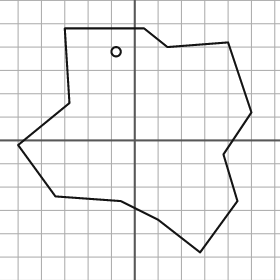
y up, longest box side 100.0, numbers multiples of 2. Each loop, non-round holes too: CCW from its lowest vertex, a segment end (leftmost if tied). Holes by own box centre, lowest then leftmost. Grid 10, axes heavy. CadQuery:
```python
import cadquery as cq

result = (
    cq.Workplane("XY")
    .moveTo(28.0, -48.0)
    .lineTo(44.0, -26.0)
    .lineTo(38.0, -6.0)
    .lineTo(50.0, 12.0)
    .lineTo(40.0, 42.0)
    .lineTo(14.0, 40.0)
    .lineTo(4.0, 48.0)
    .lineTo(-30.0, 48.0)
    .lineTo(-28.0, 16.0)
    .lineTo(-50.0, -2.0)
    .lineTo(-34.0, -24.0)
    .lineTo(-6.0, -26.0)
    .lineTo(10.0, -34.0)
    .close()
    .moveTo(-8.0, 38.0)
    .circle(2.0)
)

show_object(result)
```